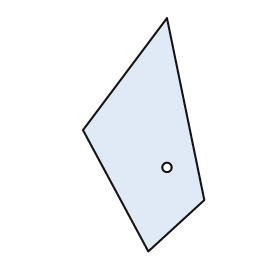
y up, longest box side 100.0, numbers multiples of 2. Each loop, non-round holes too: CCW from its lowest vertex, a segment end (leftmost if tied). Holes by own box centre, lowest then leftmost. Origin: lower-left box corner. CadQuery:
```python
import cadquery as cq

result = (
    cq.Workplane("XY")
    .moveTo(28.0, 0.0)
    .lineTo(52.0, 22.0)
    .lineTo(36.0, 100.0)
    .lineTo(0.0, 52.0)
    .close()
    .moveTo(36.0, 36.0)
    .circle(2.0)
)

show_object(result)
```